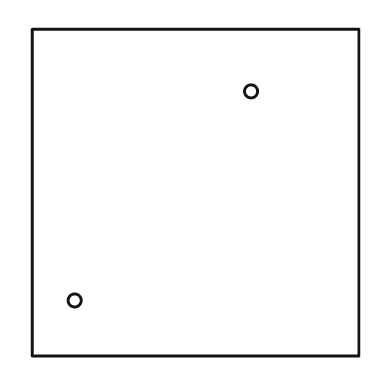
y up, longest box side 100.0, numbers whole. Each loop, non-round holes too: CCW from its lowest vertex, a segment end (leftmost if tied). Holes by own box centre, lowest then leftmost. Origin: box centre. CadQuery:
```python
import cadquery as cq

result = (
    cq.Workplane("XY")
    .moveTo(-50.0, -50.0)
    .lineTo(50.0, -50.0)
    .lineTo(50.0, 50.0)
    .lineTo(-50.0, 50.0)
    .close()
    .moveTo(-37.0, -33.0)
    .circle(2.0)
    .moveTo(17.0, 31.0)
    .circle(2.0)
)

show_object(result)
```